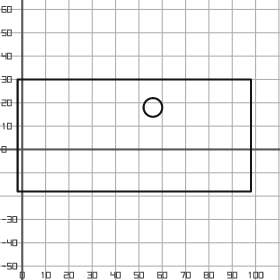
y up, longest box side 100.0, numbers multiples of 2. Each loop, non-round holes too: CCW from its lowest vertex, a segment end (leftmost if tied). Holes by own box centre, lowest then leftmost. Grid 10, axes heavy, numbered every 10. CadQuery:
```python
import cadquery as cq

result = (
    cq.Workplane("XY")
    .moveTo(-2.0, -18.0)
    .lineTo(98.0, -18.0)
    .lineTo(98.0, 30.0)
    .lineTo(-2.0, 30.0)
    .close()
    .moveTo(56.0, 18.0)
    .circle(4.0)
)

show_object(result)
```